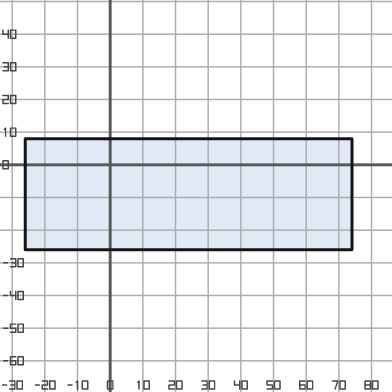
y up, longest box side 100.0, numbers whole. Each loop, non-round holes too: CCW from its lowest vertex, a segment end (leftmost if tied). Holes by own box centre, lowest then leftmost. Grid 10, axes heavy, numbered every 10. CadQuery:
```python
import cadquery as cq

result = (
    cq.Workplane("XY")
    .moveTo(-26.0, -26.0)
    .lineTo(74.0, -26.0)
    .lineTo(74.0, 8.0)
    .lineTo(-26.0, 8.0)
    .close()
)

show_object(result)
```